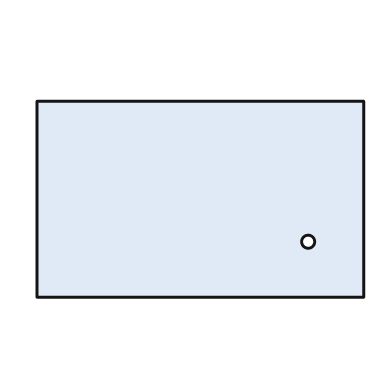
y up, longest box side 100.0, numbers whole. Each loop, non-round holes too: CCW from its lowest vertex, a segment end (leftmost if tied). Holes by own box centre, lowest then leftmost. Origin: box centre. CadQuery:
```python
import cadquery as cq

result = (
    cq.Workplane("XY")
    .moveTo(-50.0, -30.0)
    .lineTo(50.0, -30.0)
    .lineTo(50.0, 30.0)
    .lineTo(-50.0, 30.0)
    .close()
    .moveTo(33.0, -13.0)
    .circle(2.0)
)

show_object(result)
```